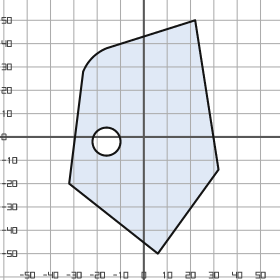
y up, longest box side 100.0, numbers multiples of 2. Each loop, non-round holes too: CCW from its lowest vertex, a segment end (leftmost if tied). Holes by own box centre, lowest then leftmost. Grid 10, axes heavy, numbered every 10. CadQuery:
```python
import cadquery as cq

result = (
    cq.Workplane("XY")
    .moveTo(6.0, -50.0)
    .lineTo(32.0, -14.0)
    .lineTo(22.0, 50.0)
    .lineTo(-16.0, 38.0)
    .threePointArc((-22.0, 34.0), (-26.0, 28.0))
    .lineTo(-32.0, -20.0)
    .close()
    .moveTo(-16.0, -2.0)
    .circle(6.0)
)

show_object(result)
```